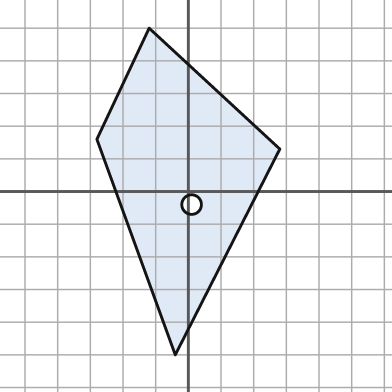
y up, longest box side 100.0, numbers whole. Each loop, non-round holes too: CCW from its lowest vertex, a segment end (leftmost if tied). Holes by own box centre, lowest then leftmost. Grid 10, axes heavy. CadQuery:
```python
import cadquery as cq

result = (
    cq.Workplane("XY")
    .moveTo(-4.0, -50.0)
    .lineTo(28.0, 13.0)
    .lineTo(-12.0, 50.0)
    .lineTo(-28.0, 16.0)
    .close()
    .moveTo(1.0, -4.0)
    .circle(3.0)
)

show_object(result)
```